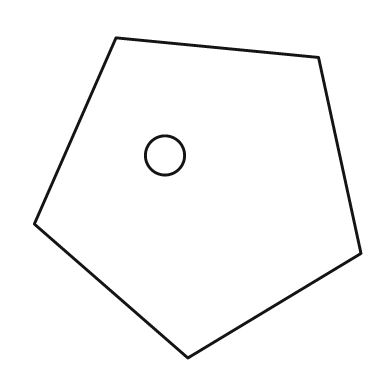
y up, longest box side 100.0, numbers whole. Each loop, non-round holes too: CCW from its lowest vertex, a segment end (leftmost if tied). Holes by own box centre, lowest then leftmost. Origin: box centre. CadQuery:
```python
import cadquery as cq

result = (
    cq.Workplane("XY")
    .moveTo(-3.0, -49.0)
    .lineTo(50.0, -17.0)
    .lineTo(37.0, 43.0)
    .lineTo(-25.0, 49.0)
    .lineTo(-50.0, -8.0)
    .close()
    .moveTo(-10.0, 13.0)
    .circle(6.0)
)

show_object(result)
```